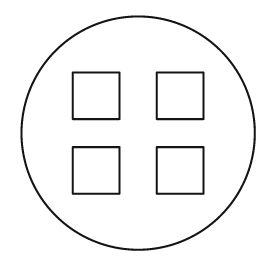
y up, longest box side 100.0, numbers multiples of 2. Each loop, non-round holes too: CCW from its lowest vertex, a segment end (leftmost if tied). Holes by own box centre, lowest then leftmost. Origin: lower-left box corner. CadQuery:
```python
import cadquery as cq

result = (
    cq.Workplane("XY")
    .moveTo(50.0, 50.0)
    .circle(50.0)
    .moveTo(22.0, 24.0)
    .lineTo(42.0, 24.0)
    .lineTo(42.0, 44.0)
    .lineTo(22.0, 44.0)
    .close()
    .moveTo(58.0, 24.0)
    .lineTo(78.0, 24.0)
    .lineTo(78.0, 44.0)
    .lineTo(58.0, 44.0)
    .close()
    .moveTo(22.0, 56.0)
    .lineTo(42.0, 56.0)
    .lineTo(42.0, 76.0)
    .lineTo(22.0, 76.0)
    .close()
    .moveTo(58.0, 56.0)
    .lineTo(78.0, 56.0)
    .lineTo(78.0, 76.0)
    .lineTo(58.0, 76.0)
    .close()
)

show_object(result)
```